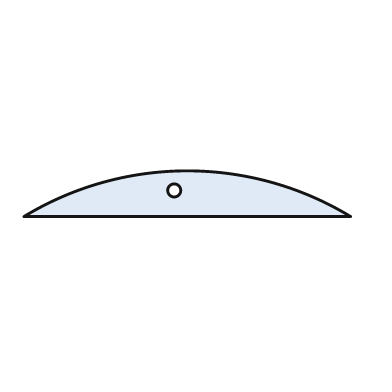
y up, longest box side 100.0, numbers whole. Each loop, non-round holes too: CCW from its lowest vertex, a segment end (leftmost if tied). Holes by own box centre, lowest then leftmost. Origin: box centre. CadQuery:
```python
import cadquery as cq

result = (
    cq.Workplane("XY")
    .moveTo(-50.0, -7.0)
    .lineTo(50.0, -7.0)
    .threePointArc((0.0, 7.0), (-50.0, -7.0))
    .close()
    .moveTo(-4.0, 1.0)
    .circle(2.0)
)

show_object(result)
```